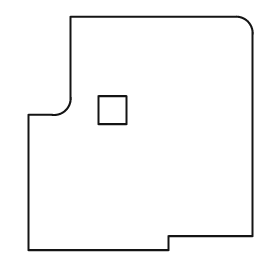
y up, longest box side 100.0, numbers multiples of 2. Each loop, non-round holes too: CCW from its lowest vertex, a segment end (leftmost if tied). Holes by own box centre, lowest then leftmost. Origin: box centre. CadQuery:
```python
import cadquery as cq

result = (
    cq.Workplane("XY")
    .moveTo(-48.0, -50.0)
    .lineTo(12.0, -50.0)
    .lineTo(12.0, -44.0)
    .lineTo(48.0, -44.0)
    .lineTo(48.0, 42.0)
    .threePointArc((46.0, 48.0), (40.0, 50.0))
    .lineTo(-30.0, 50.0)
    .lineTo(-30.0, 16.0)
    .threePointArc((-32.0, 10.0), (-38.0, 8.0))
    .lineTo(-48.0, 8.0)
    .close()
    .moveTo(-18.0, 4.0)
    .lineTo(-6.0, 4.0)
    .lineTo(-6.0, 16.0)
    .lineTo(-18.0, 16.0)
    .close()
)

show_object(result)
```